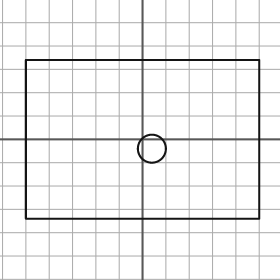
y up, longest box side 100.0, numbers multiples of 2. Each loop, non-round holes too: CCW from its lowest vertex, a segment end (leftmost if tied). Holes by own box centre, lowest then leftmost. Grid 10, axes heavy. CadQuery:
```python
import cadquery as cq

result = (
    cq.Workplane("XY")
    .moveTo(-50.0, -34.0)
    .lineTo(50.0, -34.0)
    .lineTo(50.0, 34.0)
    .lineTo(-50.0, 34.0)
    .close()
    .moveTo(4.0, -4.0)
    .circle(6.0)
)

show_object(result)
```